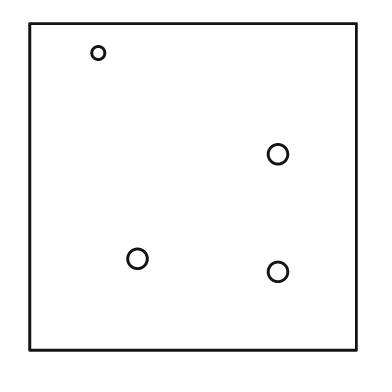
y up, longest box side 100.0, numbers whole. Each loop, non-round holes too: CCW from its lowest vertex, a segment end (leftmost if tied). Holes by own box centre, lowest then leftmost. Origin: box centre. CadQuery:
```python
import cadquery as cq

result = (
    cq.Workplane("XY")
    .moveTo(-50.0, -50.0)
    .lineTo(50.0, -50.0)
    .lineTo(50.0, 50.0)
    .lineTo(-50.0, 50.0)
    .close()
    .moveTo(26.0, -26.0)
    .circle(3.0)
    .moveTo(-17.0, -22.0)
    .circle(3.0)
    .moveTo(26.0, 10.0)
    .circle(3.0)
    .moveTo(-29.0, 41.0)
    .circle(2.0)
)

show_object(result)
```